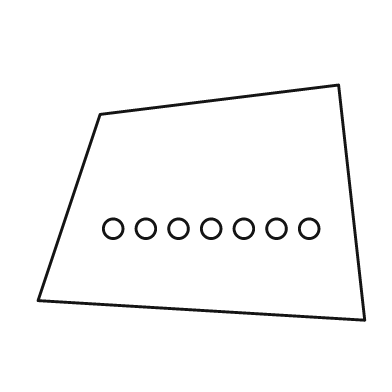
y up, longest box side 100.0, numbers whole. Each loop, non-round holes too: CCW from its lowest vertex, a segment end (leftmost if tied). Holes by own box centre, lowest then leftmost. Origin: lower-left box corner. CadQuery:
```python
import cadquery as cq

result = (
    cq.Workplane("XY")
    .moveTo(100.0, 0.0)
    .lineTo(92.0, 72.0)
    .lineTo(19.0, 63.0)
    .lineTo(0.0, 6.0)
    .close()
    .moveTo(23.0, 28.0)
    .circle(3.0)
    .moveTo(33.0, 28.0)
    .circle(3.0)
    .moveTo(43.0, 28.0)
    .circle(3.0)
    .moveTo(53.0, 28.0)
    .circle(3.0)
    .moveTo(63.0, 28.0)
    .circle(3.0)
    .moveTo(73.0, 28.0)
    .circle(3.0)
    .moveTo(83.0, 28.0)
    .circle(3.0)
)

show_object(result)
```